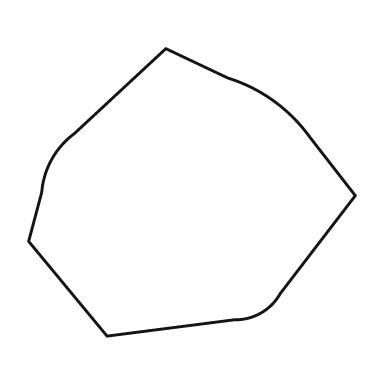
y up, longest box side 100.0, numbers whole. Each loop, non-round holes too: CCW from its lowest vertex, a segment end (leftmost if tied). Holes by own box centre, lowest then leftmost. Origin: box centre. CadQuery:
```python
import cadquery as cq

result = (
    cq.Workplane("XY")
    .moveTo(-26.0, -44.0)
    .lineTo(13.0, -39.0)
    .threePointArc((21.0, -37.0), (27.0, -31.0))
    .lineTo(50.0, -1.0)
    .lineTo(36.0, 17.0)
    .threePointArc((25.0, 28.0), (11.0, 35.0))
    .lineTo(-8.0, 44.0)
    .lineTo(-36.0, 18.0)
    .threePointArc((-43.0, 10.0), (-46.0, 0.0))
    .lineTo(-50.0, -15.0)
    .close()
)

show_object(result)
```